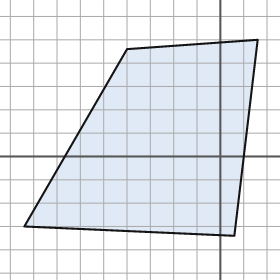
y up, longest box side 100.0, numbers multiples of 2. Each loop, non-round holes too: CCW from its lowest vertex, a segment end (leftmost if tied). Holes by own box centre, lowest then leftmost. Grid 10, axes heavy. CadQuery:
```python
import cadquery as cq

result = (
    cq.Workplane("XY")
    .moveTo(6.0, -34.0)
    .lineTo(16.0, 50.0)
    .lineTo(-40.0, 46.0)
    .lineTo(-84.0, -30.0)
    .close()
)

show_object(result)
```